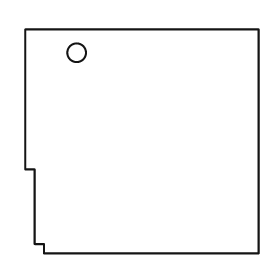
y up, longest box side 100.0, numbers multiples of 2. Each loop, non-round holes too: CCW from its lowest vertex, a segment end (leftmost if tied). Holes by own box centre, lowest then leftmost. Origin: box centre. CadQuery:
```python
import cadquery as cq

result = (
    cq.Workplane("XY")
    .moveTo(-42.0, -48.0)
    .lineTo(50.0, -48.0)
    .lineTo(50.0, 48.0)
    .lineTo(-50.0, 48.0)
    .lineTo(-50.0, -12.0)
    .lineTo(-46.0, -12.0)
    .lineTo(-46.0, -44.0)
    .lineTo(-42.0, -44.0)
    .close()
    .moveTo(-28.0, 38.0)
    .circle(4.0)
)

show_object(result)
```